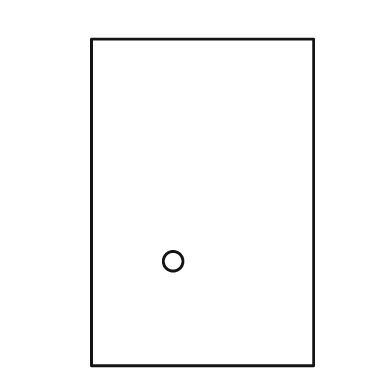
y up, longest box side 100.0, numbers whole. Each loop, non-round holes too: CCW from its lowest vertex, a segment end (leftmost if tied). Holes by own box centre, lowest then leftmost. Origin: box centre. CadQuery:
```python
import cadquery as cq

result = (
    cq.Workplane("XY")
    .moveTo(-34.0, -50.0)
    .lineTo(34.0, -50.0)
    .lineTo(34.0, 50.0)
    .lineTo(-34.0, 50.0)
    .close()
    .moveTo(-9.0, -18.0)
    .circle(3.0)
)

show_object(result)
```